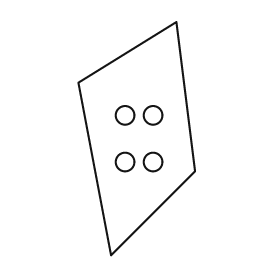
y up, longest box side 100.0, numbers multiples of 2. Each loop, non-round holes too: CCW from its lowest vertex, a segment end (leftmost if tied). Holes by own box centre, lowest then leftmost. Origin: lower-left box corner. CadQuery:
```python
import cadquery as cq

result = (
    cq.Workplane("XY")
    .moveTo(14.0, 0.0)
    .lineTo(50.0, 36.0)
    .lineTo(42.0, 100.0)
    .lineTo(0.0, 74.0)
    .close()
    .moveTo(20.0, 40.0)
    .circle(4.0)
    .moveTo(32.0, 40.0)
    .circle(4.0)
    .moveTo(20.0, 60.0)
    .circle(4.0)
    .moveTo(32.0, 60.0)
    .circle(4.0)
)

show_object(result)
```